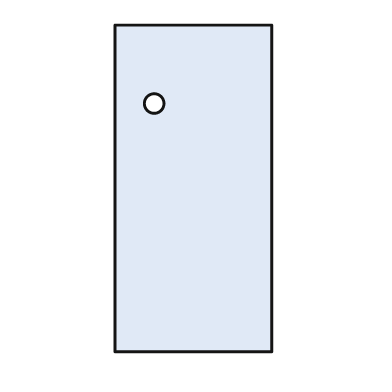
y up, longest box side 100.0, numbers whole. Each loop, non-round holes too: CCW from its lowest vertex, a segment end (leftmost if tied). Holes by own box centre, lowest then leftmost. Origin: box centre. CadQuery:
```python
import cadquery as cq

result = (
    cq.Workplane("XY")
    .moveTo(-24.0, -50.0)
    .lineTo(24.0, -50.0)
    .lineTo(24.0, 50.0)
    .lineTo(-24.0, 50.0)
    .close()
    .moveTo(-12.0, 26.0)
    .circle(3.0)
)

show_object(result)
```